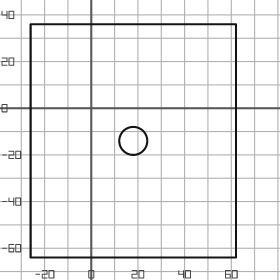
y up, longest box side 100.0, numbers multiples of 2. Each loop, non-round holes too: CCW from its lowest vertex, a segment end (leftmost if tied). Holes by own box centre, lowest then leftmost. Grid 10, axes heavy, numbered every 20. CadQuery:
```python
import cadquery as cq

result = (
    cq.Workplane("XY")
    .moveTo(-26.0, -64.0)
    .lineTo(62.0, -64.0)
    .lineTo(62.0, 36.0)
    .lineTo(-26.0, 36.0)
    .close()
    .moveTo(18.0, -14.0)
    .circle(6.0)
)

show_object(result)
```